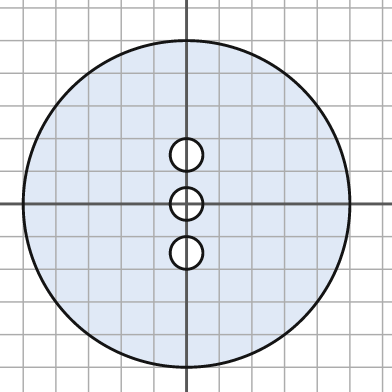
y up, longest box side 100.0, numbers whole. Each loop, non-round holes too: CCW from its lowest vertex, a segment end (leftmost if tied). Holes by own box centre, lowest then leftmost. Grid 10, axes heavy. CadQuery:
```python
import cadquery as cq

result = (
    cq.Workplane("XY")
    .moveTo(0.0, 0.0)
    .circle(50.0)
    .moveTo(0.0, -15.0)
    .circle(5.0)
    .moveTo(0.0, 0.0)
    .circle(5.0)
    .moveTo(0.0, 15.0)
    .circle(5.0)
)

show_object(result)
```